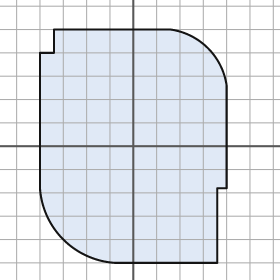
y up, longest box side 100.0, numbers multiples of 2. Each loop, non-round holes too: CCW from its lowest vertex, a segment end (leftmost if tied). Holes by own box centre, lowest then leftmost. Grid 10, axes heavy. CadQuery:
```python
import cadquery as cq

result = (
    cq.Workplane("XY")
    .moveTo(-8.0, -50.0)
    .lineTo(36.0, -50.0)
    .lineTo(36.0, -18.0)
    .lineTo(40.0, -18.0)
    .lineTo(40.0, 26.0)
    .threePointArc((32.0, 42.0), (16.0, 50.0))
    .lineTo(-34.0, 50.0)
    .lineTo(-34.0, 40.0)
    .lineTo(-40.0, 40.0)
    .lineTo(-40.0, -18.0)
    .threePointArc((-30.0, -40.0), (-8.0, -50.0))
    .close()
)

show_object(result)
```